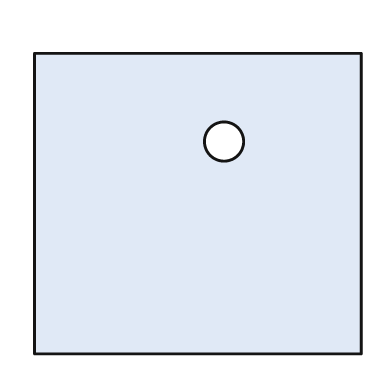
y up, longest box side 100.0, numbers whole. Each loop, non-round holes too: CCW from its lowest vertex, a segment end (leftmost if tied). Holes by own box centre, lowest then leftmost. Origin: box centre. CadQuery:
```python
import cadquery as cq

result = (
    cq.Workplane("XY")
    .moveTo(-50.0, -46.0)
    .lineTo(50.0, -46.0)
    .lineTo(50.0, 46.0)
    .lineTo(-50.0, 46.0)
    .close()
    .moveTo(8.0, 19.0)
    .circle(6.0)
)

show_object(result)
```